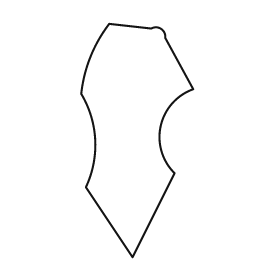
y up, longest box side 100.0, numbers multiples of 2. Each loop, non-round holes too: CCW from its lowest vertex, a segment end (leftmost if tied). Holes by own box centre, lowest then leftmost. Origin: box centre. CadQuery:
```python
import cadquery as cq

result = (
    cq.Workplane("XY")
    .moveTo(-2.0, -50.0)
    .lineTo(16.0, -14.0)
    .threePointArc((10.0, 6.0), (24.0, 22.0))
    .lineTo(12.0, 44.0)
    .threePointArc((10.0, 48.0), (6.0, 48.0))
    .lineTo(-12.0, 50.0)
    .threePointArc((-20.0, 36.0), (-24.0, 20.0))
    .threePointArc((-18.0, 0.0), (-22.0, -20.0))
    .close()
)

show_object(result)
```